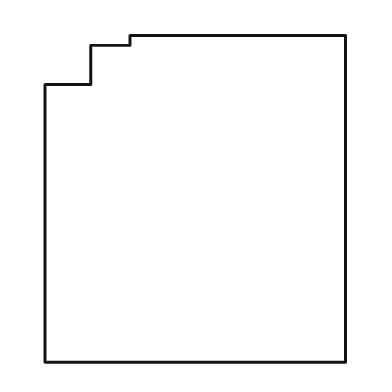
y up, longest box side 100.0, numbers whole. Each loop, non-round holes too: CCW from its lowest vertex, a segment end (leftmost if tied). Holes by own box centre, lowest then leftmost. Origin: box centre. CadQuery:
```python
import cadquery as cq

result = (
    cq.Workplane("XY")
    .moveTo(-46.0, -50.0)
    .lineTo(46.0, -50.0)
    .lineTo(46.0, 50.0)
    .lineTo(-20.0, 50.0)
    .lineTo(-20.0, 47.0)
    .lineTo(-32.0, 47.0)
    .lineTo(-32.0, 35.0)
    .lineTo(-46.0, 35.0)
    .close()
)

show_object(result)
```